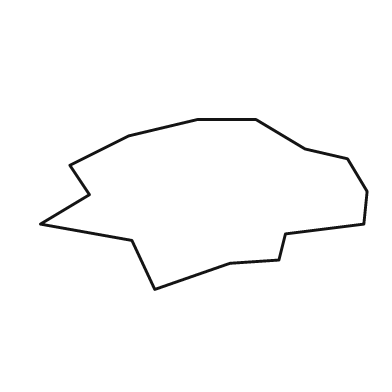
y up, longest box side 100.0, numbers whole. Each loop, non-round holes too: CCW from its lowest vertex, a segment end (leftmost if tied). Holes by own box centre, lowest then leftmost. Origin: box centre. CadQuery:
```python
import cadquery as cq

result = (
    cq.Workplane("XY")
    .moveTo(-15.0, -26.0)
    .lineTo(8.0, -18.0)
    .lineTo(23.0, -17.0)
    .lineTo(25.0, -9.0)
    .lineTo(49.0, -6.0)
    .lineTo(50.0, 4.0)
    .lineTo(44.0, 14.0)
    .lineTo(31.0, 17.0)
    .lineTo(16.0, 26.0)
    .lineTo(-2.0, 26.0)
    .lineTo(-23.0, 21.0)
    .lineTo(-41.0, 12.0)
    .lineTo(-35.0, 3.0)
    .lineTo(-50.0, -6.0)
    .lineTo(-22.0, -11.0)
    .close()
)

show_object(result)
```